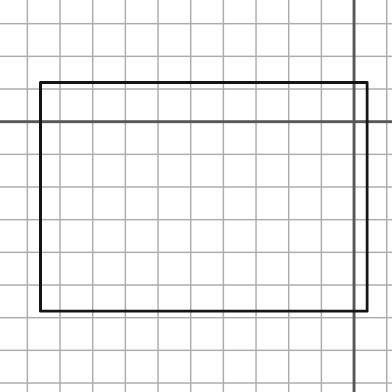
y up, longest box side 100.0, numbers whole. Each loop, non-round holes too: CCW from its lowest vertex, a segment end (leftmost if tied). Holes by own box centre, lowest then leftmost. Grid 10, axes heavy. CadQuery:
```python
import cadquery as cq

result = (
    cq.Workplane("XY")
    .moveTo(-96.0, -58.0)
    .lineTo(4.0, -58.0)
    .lineTo(4.0, 12.0)
    .lineTo(-96.0, 12.0)
    .close()
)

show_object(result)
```